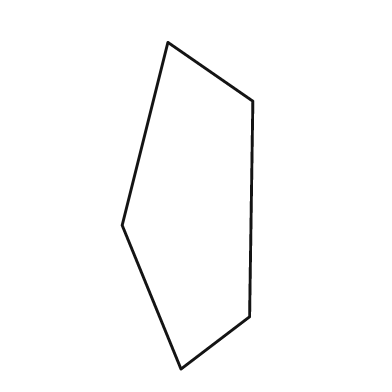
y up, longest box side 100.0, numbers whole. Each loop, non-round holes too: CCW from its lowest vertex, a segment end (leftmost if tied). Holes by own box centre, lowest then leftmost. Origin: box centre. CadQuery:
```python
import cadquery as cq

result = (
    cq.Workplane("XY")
    .moveTo(-2.0, -50.0)
    .lineTo(19.0, -34.0)
    .lineTo(20.0, 32.0)
    .lineTo(-6.0, 50.0)
    .lineTo(-20.0, -6.0)
    .close()
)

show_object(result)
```